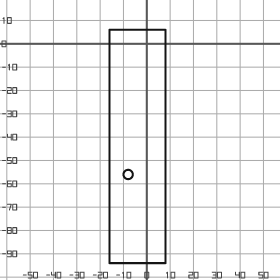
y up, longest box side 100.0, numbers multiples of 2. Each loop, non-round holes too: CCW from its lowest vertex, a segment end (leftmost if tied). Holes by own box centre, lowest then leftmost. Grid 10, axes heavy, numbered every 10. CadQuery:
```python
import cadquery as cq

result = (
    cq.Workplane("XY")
    .moveTo(-16.0, -94.0)
    .lineTo(8.0, -94.0)
    .lineTo(8.0, 6.0)
    .lineTo(-16.0, 6.0)
    .close()
    .moveTo(-8.0, -56.0)
    .circle(2.0)
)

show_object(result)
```